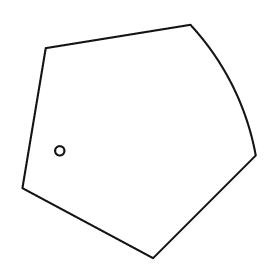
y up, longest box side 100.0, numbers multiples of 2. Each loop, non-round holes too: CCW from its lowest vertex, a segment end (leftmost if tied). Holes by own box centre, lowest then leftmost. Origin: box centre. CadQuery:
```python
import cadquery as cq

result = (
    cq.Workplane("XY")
    .moveTo(6.0, -50.0)
    .lineTo(50.0, -6.0)
    .threePointArc((40.0, 24.0), (22.0, 50.0))
    .lineTo(-40.0, 40.0)
    .lineTo(-50.0, -20.0)
    .close()
    .moveTo(-34.0, -4.0)
    .circle(2.0)
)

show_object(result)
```